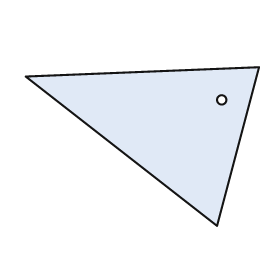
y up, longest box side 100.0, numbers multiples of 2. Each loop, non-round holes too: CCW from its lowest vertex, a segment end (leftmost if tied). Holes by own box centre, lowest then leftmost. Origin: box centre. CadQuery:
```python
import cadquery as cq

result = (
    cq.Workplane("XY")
    .moveTo(32.0, -34.0)
    .lineTo(50.0, 34.0)
    .lineTo(-50.0, 30.0)
    .close()
    .moveTo(34.0, 20.0)
    .circle(2.0)
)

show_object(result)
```